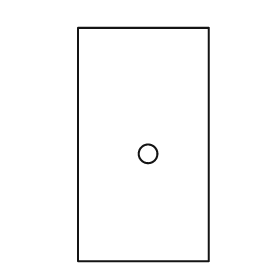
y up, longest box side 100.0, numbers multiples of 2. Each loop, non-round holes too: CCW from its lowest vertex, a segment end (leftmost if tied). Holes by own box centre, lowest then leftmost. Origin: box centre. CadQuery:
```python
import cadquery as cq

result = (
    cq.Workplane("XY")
    .moveTo(-28.0, -50.0)
    .lineTo(28.0, -50.0)
    .lineTo(28.0, 50.0)
    .lineTo(-28.0, 50.0)
    .close()
    .moveTo(2.0, -4.0)
    .circle(4.0)
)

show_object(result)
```